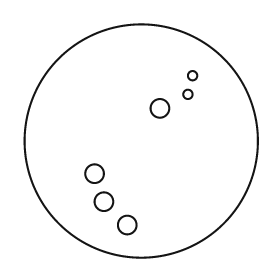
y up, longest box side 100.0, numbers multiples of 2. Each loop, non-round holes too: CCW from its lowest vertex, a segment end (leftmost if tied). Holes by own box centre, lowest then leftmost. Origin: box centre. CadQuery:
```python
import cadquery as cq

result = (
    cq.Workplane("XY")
    .moveTo(0.0, 0.0)
    .circle(50.0)
    .moveTo(-6.0, -36.0)
    .circle(4.0)
    .moveTo(-16.0, -26.0)
    .circle(4.0)
    .moveTo(-20.0, -14.0)
    .circle(4.0)
    .moveTo(8.0, 14.0)
    .circle(4.0)
    .moveTo(20.0, 20.0)
    .circle(2.0)
    .moveTo(22.0, 28.0)
    .circle(2.0)
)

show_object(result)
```